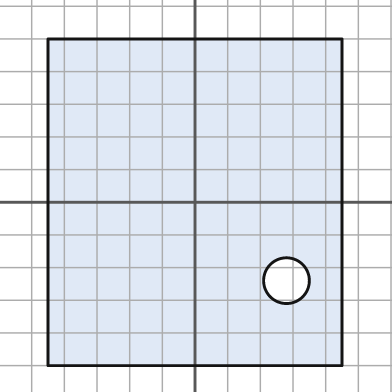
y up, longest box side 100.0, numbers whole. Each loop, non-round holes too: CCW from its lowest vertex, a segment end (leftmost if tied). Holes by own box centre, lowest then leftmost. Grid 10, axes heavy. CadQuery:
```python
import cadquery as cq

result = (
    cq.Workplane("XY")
    .moveTo(-45.0, -50.0)
    .lineTo(45.0, -50.0)
    .lineTo(45.0, 50.0)
    .lineTo(-45.0, 50.0)
    .close()
    .moveTo(28.0, -24.0)
    .circle(7.0)
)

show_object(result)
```